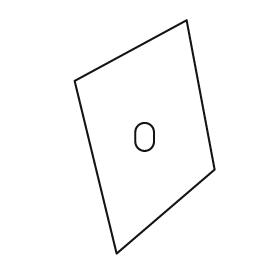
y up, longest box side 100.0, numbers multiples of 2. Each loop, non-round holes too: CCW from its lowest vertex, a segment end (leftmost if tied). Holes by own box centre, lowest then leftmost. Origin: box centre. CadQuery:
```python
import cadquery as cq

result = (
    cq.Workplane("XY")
    .moveTo(-12.0, -50.0)
    .lineTo(30.0, -14.0)
    .lineTo(18.0, 50.0)
    .lineTo(-30.0, 24.0)
    .close()
    .moveTo(-4.0, -2.0)
    .threePointArc((0.0, -6.0), (4.0, -2.0))
    .lineTo(4.0, 2.0)
    .threePointArc((0.0, 6.0), (-4.0, 2.0))
    .close()
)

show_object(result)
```